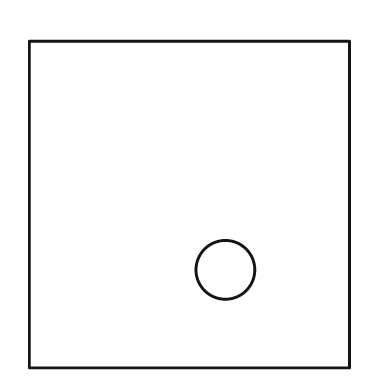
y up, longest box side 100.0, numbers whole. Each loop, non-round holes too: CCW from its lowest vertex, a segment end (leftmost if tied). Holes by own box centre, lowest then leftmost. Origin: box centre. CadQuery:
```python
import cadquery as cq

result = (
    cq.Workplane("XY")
    .moveTo(-49.0, -50.0)
    .lineTo(49.0, -50.0)
    .lineTo(49.0, 50.0)
    .lineTo(-49.0, 50.0)
    .close()
    .moveTo(11.0, -20.0)
    .circle(9.0)
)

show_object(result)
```